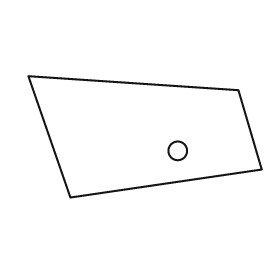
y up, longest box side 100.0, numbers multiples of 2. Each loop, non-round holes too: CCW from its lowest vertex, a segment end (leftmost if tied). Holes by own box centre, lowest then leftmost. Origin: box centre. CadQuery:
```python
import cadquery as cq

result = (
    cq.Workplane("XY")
    .moveTo(-32.0, -26.0)
    .lineTo(50.0, -14.0)
    .lineTo(40.0, 20.0)
    .lineTo(-50.0, 26.0)
    .close()
    .moveTo(14.0, -6.0)
    .circle(4.0)
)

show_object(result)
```